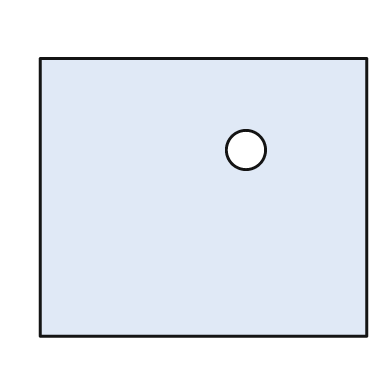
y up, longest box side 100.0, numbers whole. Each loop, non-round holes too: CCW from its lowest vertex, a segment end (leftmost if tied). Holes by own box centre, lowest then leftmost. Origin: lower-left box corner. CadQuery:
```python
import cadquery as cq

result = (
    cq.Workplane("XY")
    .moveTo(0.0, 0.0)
    .lineTo(100.0, 0.0)
    .lineTo(100.0, 85.0)
    .lineTo(0.0, 85.0)
    .close()
    .moveTo(63.0, 57.0)
    .circle(6.0)
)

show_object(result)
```